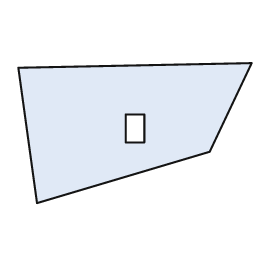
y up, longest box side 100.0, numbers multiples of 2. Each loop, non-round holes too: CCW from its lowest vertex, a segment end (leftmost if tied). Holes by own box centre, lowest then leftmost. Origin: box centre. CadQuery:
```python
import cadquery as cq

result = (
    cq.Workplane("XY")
    .moveTo(-42.0, -30.0)
    .lineTo(32.0, -8.0)
    .lineTo(50.0, 30.0)
    .lineTo(-50.0, 28.0)
    .close()
    .moveTo(-4.0, -4.0)
    .lineTo(4.0, -4.0)
    .lineTo(4.0, 8.0)
    .lineTo(-4.0, 8.0)
    .close()
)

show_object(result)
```